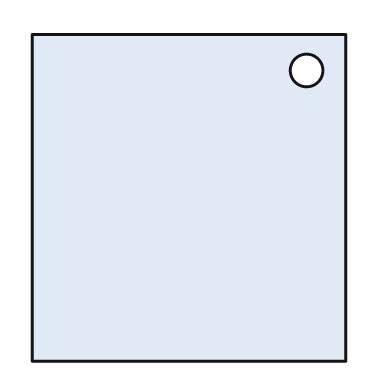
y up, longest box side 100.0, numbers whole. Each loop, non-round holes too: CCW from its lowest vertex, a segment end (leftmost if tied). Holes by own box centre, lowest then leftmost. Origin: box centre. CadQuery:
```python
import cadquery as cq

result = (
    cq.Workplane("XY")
    .moveTo(-48.0, -50.0)
    .lineTo(48.0, -50.0)
    .lineTo(48.0, 50.0)
    .lineTo(-48.0, 50.0)
    .close()
    .moveTo(36.0, 39.0)
    .circle(5.0)
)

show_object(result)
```